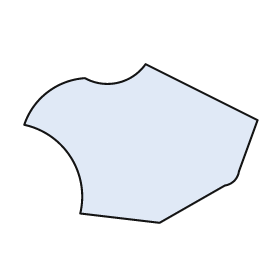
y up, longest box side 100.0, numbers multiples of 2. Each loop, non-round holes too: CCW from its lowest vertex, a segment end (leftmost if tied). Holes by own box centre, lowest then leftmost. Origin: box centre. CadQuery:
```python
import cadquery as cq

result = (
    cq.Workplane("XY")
    .moveTo(8.0, -34.0)
    .lineTo(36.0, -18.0)
    .threePointArc((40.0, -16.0), (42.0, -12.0))
    .lineTo(50.0, 10.0)
    .lineTo(2.0, 34.0)
    .threePointArc((-10.0, 26.0), (-24.0, 28.0))
    .threePointArc((-40.0, 22.0), (-50.0, 8.0))
    .threePointArc((-30.0, -6.0), (-26.0, -30.0))
    .close()
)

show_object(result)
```